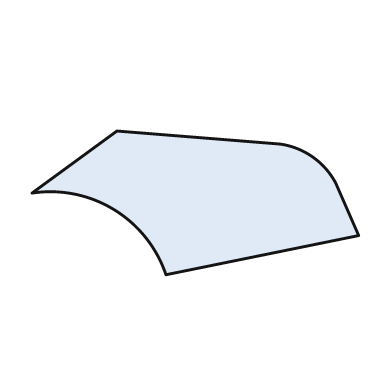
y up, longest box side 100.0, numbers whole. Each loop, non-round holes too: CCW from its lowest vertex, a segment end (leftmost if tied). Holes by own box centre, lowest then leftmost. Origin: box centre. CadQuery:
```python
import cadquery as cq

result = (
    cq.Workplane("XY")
    .moveTo(-9.0, -22.0)
    .lineTo(50.0, -10.0)
    .lineTo(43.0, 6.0)
    .threePointArc((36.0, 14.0), (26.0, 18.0))
    .lineTo(-24.0, 22.0)
    .lineTo(-50.0, 3.0)
    .threePointArc((-25.0, -2.0), (-9.0, -22.0))
    .close()
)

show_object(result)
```